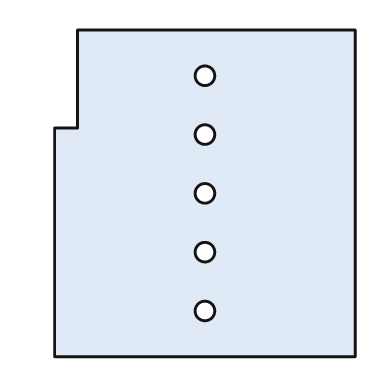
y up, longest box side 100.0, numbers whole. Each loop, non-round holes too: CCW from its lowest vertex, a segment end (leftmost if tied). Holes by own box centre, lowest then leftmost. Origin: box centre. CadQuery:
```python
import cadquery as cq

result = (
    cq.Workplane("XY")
    .moveTo(-46.0, -50.0)
    .lineTo(46.0, -50.0)
    .lineTo(46.0, 50.0)
    .lineTo(-39.0, 50.0)
    .lineTo(-39.0, 20.0)
    .lineTo(-46.0, 20.0)
    .close()
    .moveTo(0.0, -36.0)
    .circle(3.0)
    .moveTo(0.0, -18.0)
    .circle(3.0)
    .moveTo(0.0, 0.0)
    .circle(3.0)
    .moveTo(0.0, 18.0)
    .circle(3.0)
    .moveTo(0.0, 36.0)
    .circle(3.0)
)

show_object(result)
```